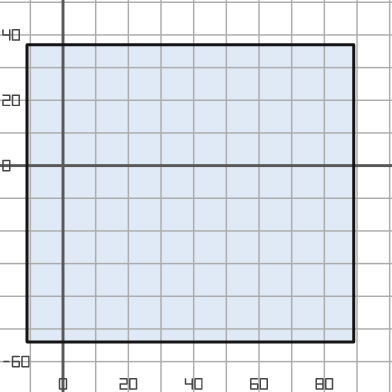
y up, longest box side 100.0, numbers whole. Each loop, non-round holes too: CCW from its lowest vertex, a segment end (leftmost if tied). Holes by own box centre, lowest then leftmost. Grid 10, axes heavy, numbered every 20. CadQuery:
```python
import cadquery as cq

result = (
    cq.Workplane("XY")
    .moveTo(-11.0, -54.0)
    .lineTo(89.0, -54.0)
    .lineTo(89.0, 37.0)
    .lineTo(-11.0, 37.0)
    .close()
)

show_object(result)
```